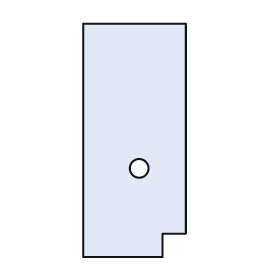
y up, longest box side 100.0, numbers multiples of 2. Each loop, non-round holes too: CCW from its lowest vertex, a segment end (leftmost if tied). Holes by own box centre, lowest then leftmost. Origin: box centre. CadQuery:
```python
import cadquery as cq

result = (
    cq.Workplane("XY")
    .moveTo(-22.0, -50.0)
    .lineTo(12.0, -50.0)
    .lineTo(12.0, -40.0)
    .lineTo(22.0, -40.0)
    .lineTo(22.0, 50.0)
    .lineTo(-22.0, 50.0)
    .close()
    .moveTo(2.0, -12.0)
    .circle(4.0)
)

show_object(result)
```